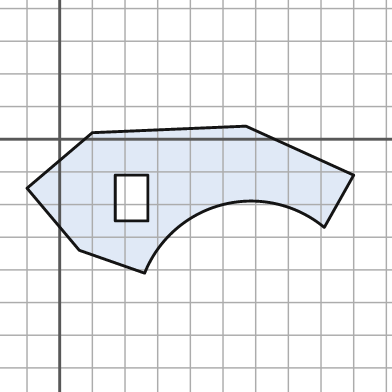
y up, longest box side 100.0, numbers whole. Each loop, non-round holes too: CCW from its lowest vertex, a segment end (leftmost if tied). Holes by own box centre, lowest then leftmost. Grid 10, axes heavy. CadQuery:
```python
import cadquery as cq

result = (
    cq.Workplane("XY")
    .moveTo(26.0, -41.0)
    .threePointArc((50.0, -20.0), (81.0, -27.0))
    .lineTo(90.0, -11.0)
    .lineTo(57.0, 4.0)
    .lineTo(10.0, 2.0)
    .lineTo(-10.0, -15.0)
    .lineTo(6.0, -34.0)
    .close()
    .moveTo(17.0, -25.0)
    .lineTo(27.0, -25.0)
    .lineTo(27.0, -11.0)
    .lineTo(17.0, -11.0)
    .close()
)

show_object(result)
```